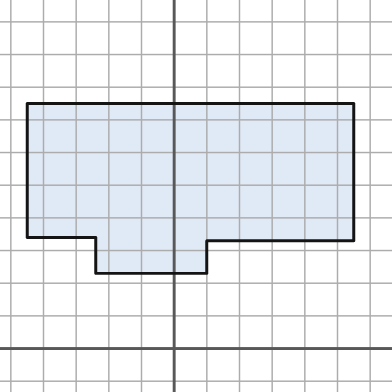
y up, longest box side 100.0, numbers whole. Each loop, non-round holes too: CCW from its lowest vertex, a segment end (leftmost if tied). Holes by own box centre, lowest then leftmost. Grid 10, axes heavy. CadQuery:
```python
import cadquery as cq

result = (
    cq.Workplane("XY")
    .moveTo(-24.0, 23.0)
    .lineTo(10.0, 23.0)
    .lineTo(10.0, 33.0)
    .lineTo(55.0, 33.0)
    .lineTo(55.0, 75.0)
    .lineTo(-45.0, 75.0)
    .lineTo(-45.0, 34.0)
    .lineTo(-24.0, 34.0)
    .close()
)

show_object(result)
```